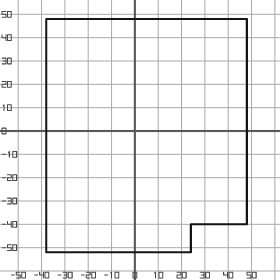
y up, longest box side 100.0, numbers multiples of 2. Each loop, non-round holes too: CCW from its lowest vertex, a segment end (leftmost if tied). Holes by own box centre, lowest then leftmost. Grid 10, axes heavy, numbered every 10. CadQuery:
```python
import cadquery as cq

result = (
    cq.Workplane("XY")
    .moveTo(-38.0, -52.0)
    .lineTo(24.0, -52.0)
    .lineTo(24.0, -40.0)
    .lineTo(48.0, -40.0)
    .lineTo(48.0, 48.0)
    .lineTo(-38.0, 48.0)
    .close()
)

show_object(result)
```